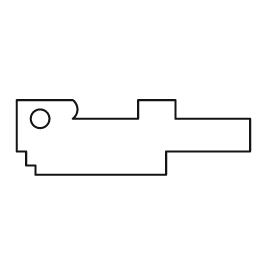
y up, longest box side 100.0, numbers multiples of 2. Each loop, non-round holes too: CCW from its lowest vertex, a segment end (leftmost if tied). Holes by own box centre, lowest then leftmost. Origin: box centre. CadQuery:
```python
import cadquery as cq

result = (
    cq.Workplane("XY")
    .moveTo(-42.0, -16.0)
    .lineTo(14.0, -16.0)
    .lineTo(14.0, -6.0)
    .lineTo(50.0, -6.0)
    .lineTo(50.0, 8.0)
    .lineTo(18.0, 8.0)
    .lineTo(18.0, 16.0)
    .lineTo(2.0, 16.0)
    .lineTo(2.0, 8.0)
    .lineTo(-26.0, 8.0)
    .threePointArc((-24.0, 12.0), (-26.0, 16.0))
    .lineTo(-50.0, 16.0)
    .lineTo(-50.0, -6.0)
    .lineTo(-46.0, -6.0)
    .lineTo(-46.0, -12.0)
    .lineTo(-42.0, -12.0)
    .close()
    .moveTo(-40.0, 8.0)
    .circle(4.0)
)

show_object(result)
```